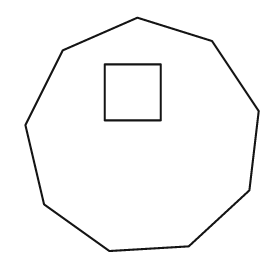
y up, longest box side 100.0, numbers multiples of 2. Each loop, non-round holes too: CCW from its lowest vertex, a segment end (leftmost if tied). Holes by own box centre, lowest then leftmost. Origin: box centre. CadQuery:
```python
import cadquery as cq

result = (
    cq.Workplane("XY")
    .moveTo(-14.0, -50.0)
    .lineTo(20.0, -48.0)
    .lineTo(46.0, -24.0)
    .lineTo(50.0, 10.0)
    .lineTo(30.0, 40.0)
    .lineTo(-2.0, 50.0)
    .lineTo(-34.0, 36.0)
    .lineTo(-50.0, 4.0)
    .lineTo(-42.0, -30.0)
    .close()
    .moveTo(-16.0, 6.0)
    .lineTo(8.0, 6.0)
    .lineTo(8.0, 30.0)
    .lineTo(-16.0, 30.0)
    .close()
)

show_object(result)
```